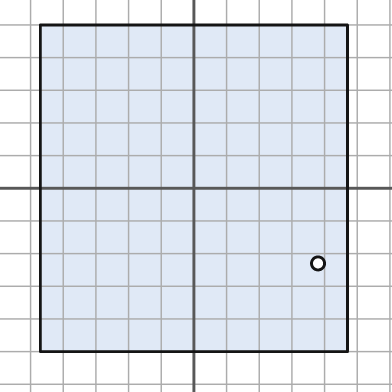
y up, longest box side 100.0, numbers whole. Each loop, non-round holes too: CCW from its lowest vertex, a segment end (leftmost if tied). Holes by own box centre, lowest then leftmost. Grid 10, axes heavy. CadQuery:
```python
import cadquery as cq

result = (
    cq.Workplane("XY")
    .moveTo(-47.0, -50.0)
    .lineTo(47.0, -50.0)
    .lineTo(47.0, 50.0)
    .lineTo(-47.0, 50.0)
    .close()
    .moveTo(38.0, -23.0)
    .circle(2.0)
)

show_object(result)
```